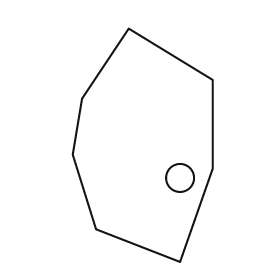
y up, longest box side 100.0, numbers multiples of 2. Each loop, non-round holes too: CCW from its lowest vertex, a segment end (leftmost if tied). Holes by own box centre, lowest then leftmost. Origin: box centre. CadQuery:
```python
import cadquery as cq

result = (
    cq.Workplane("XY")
    .moveTo(16.0, -50.0)
    .lineTo(30.0, -10.0)
    .lineTo(30.0, 28.0)
    .lineTo(-6.0, 50.0)
    .lineTo(-26.0, 20.0)
    .lineTo(-30.0, -4.0)
    .lineTo(-20.0, -36.0)
    .close()
    .moveTo(16.0, -14.0)
    .circle(6.0)
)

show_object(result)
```